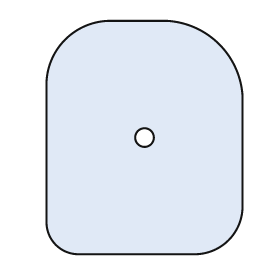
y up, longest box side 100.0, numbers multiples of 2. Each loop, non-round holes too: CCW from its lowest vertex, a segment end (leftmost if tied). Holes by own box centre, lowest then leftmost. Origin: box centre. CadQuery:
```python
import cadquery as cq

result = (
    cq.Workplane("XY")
    .moveTo(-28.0, -50.0)
    .lineTo(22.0, -50.0)
    .threePointArc((36.0, -44.0), (42.0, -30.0))
    .lineTo(42.0, 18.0)
    .threePointArc((32.0, 40.0), (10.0, 50.0))
    .lineTo(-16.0, 50.0)
    .threePointArc((-34.0, 42.0), (-42.0, 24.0))
    .lineTo(-42.0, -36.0)
    .threePointArc((-38.0, -46.0), (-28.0, -50.0))
    .close()
    .moveTo(0.0, 0.0)
    .circle(4.0)
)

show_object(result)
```